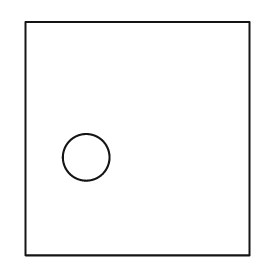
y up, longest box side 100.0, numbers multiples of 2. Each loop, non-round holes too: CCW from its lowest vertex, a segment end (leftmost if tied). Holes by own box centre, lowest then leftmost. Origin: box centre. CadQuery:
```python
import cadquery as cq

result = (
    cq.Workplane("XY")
    .moveTo(-48.0, -50.0)
    .lineTo(48.0, -50.0)
    .lineTo(48.0, 50.0)
    .lineTo(-48.0, 50.0)
    .close()
    .moveTo(-22.0, -8.0)
    .circle(10.0)
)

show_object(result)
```